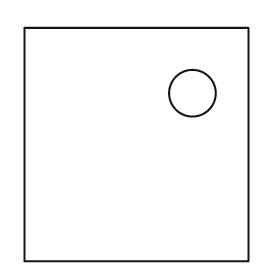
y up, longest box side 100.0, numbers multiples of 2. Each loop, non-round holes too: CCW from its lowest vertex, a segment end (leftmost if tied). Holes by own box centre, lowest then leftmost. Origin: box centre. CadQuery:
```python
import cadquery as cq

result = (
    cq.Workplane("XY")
    .moveTo(-48.0, -50.0)
    .lineTo(48.0, -50.0)
    .lineTo(48.0, 50.0)
    .lineTo(-48.0, 50.0)
    .close()
    .moveTo(24.0, 22.0)
    .circle(10.0)
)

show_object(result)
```